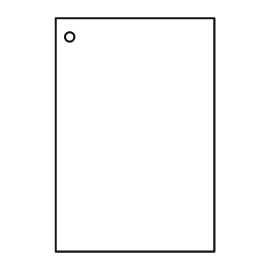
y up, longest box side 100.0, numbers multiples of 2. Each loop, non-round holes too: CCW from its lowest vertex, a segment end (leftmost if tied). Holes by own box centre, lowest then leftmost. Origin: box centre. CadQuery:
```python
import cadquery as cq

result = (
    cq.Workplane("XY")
    .moveTo(-34.0, -50.0)
    .lineTo(34.0, -50.0)
    .lineTo(34.0, 50.0)
    .lineTo(-34.0, 50.0)
    .close()
    .moveTo(-28.0, 42.0)
    .circle(2.0)
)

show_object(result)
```